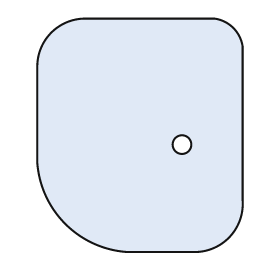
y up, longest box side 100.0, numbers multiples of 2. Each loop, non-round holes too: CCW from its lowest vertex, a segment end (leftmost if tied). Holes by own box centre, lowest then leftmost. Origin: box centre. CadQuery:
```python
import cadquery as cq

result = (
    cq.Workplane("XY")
    .moveTo(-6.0, -50.0)
    .lineTo(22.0, -50.0)
    .threePointArc((38.0, -44.0), (44.0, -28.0))
    .lineTo(44.0, 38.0)
    .threePointArc((40.0, 46.0), (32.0, 50.0))
    .lineTo(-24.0, 50.0)
    .threePointArc((-38.0, 44.0), (-44.0, 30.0))
    .lineTo(-44.0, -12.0)
    .threePointArc((-32.0, -38.0), (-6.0, -50.0))
    .close()
    .moveTo(18.0, -4.0)
    .circle(4.0)
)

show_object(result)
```